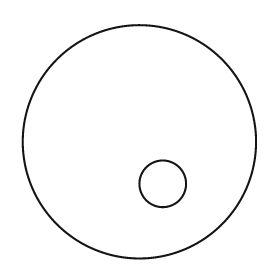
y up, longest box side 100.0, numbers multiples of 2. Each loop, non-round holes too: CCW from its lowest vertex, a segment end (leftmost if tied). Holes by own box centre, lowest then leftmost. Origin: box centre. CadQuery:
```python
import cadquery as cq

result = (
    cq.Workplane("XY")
    .moveTo(0.0, 0.0)
    .circle(50.0)
    .moveTo(10.0, -18.0)
    .circle(10.0)
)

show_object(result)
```